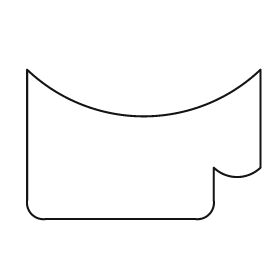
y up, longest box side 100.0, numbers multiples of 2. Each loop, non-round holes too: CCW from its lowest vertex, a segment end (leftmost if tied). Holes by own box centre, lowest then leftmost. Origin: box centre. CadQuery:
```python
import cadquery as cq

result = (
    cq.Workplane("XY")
    .moveTo(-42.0, -32.0)
    .lineTo(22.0, -32.0)
    .threePointArc((28.0, -30.0), (30.0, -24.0))
    .lineTo(30.0, -10.0)
    .threePointArc((40.0, -14.0), (50.0, -10.0))
    .lineTo(50.0, 32.0)
    .threePointArc((0.0, 12.0), (-50.0, 32.0))
    .lineTo(-50.0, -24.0)
    .threePointArc((-48.0, -30.0), (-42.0, -32.0))
    .close()
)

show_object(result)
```